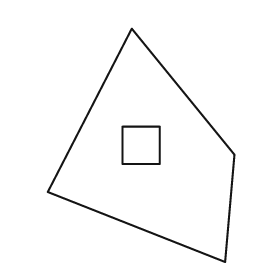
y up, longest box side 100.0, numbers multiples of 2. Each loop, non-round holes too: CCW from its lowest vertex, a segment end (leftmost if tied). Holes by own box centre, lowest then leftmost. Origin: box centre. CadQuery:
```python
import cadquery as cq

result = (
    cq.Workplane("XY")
    .moveTo(36.0, -50.0)
    .lineTo(40.0, -4.0)
    .lineTo(-4.0, 50.0)
    .lineTo(-40.0, -20.0)
    .close()
    .moveTo(-8.0, -8.0)
    .lineTo(8.0, -8.0)
    .lineTo(8.0, 8.0)
    .lineTo(-8.0, 8.0)
    .close()
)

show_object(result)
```